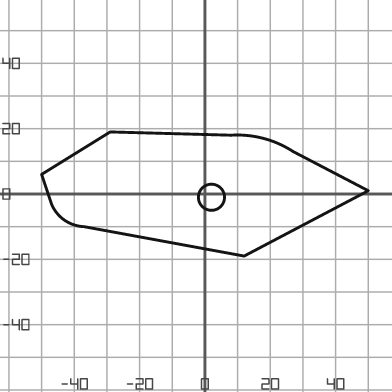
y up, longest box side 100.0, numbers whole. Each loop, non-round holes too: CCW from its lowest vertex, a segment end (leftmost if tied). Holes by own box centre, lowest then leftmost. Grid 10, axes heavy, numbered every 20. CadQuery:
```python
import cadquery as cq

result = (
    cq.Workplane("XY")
    .moveTo(12.0, -19.0)
    .lineTo(50.0, 1.0)
    .lineTo(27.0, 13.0)
    .threePointArc((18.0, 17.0), (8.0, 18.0))
    .lineTo(-29.0, 19.0)
    .lineTo(-50.0, 6.0)
    .lineTo(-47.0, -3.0)
    .threePointArc((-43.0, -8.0), (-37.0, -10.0))
    .close()
    .moveTo(2.0, -1.0)
    .circle(4.0)
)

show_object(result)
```